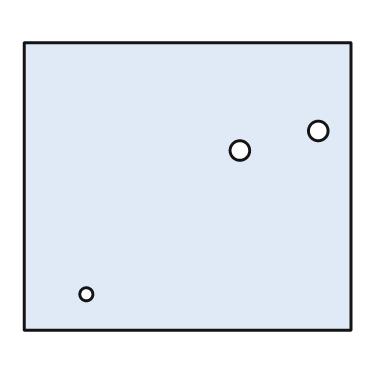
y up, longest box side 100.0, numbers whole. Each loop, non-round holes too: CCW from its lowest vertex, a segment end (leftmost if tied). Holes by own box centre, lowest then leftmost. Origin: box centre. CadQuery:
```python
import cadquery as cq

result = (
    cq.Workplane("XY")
    .moveTo(-50.0, -44.0)
    .lineTo(50.0, -44.0)
    .lineTo(50.0, 44.0)
    .lineTo(-50.0, 44.0)
    .close()
    .moveTo(-31.0, -33.0)
    .circle(2.0)
    .moveTo(16.0, 11.0)
    .circle(3.0)
    .moveTo(40.0, 17.0)
    .circle(3.0)
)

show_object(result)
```